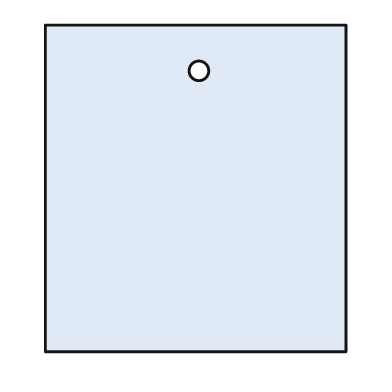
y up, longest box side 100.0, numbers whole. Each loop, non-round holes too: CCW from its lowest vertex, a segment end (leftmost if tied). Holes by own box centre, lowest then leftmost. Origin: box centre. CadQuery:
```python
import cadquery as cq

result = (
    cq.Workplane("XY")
    .moveTo(-46.0, -50.0)
    .lineTo(46.0, -50.0)
    .lineTo(46.0, 50.0)
    .lineTo(-46.0, 50.0)
    .close()
    .moveTo(1.0, 36.0)
    .circle(3.0)
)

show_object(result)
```